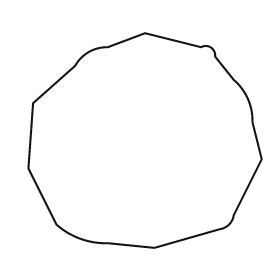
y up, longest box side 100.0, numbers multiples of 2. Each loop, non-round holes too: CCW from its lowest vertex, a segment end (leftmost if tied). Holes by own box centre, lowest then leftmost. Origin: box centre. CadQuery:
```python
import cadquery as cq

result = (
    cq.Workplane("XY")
    .moveTo(4.0, -46.0)
    .lineTo(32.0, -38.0)
    .threePointArc((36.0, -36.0), (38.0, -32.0))
    .lineTo(50.0, -8.0)
    .lineTo(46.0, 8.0)
    .threePointArc((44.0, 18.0), (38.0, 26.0))
    .lineTo(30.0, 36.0)
    .threePointArc((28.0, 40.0), (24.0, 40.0))
    .lineTo(0.0, 46.0)
    .lineTo(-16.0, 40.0)
    .threePointArc((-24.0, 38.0), (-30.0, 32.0))
    .lineTo(-48.0, 16.0)
    .lineTo(-50.0, -12.0)
    .lineTo(-38.0, -36.0)
    .threePointArc((-28.0, -42.0), (-16.0, -44.0))
    .close()
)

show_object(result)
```